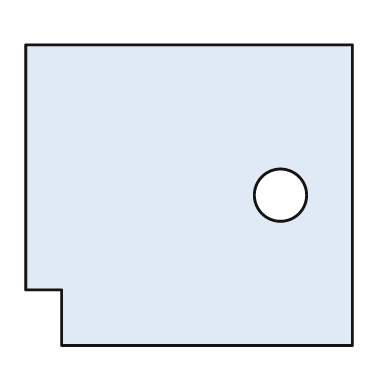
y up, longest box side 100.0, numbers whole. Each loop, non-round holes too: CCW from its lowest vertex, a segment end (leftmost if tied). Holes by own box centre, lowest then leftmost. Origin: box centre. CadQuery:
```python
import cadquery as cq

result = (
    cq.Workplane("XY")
    .moveTo(-39.0, -46.0)
    .lineTo(50.0, -46.0)
    .lineTo(50.0, 46.0)
    .lineTo(-50.0, 46.0)
    .lineTo(-50.0, -29.0)
    .lineTo(-39.0, -29.0)
    .close()
    .moveTo(28.0, 0.0)
    .circle(8.0)
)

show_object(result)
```